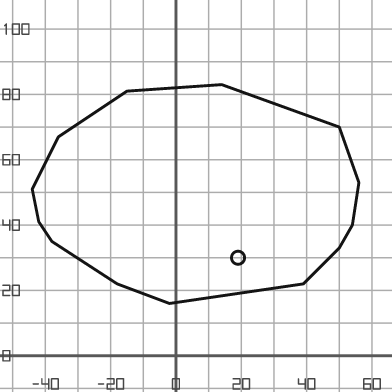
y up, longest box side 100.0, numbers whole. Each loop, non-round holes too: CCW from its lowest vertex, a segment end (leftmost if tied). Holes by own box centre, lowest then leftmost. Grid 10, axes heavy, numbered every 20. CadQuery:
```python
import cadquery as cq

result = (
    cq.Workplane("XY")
    .moveTo(-2.0, 16.0)
    .lineTo(39.0, 22.0)
    .lineTo(50.0, 33.0)
    .lineTo(54.0, 40.0)
    .lineTo(56.0, 53.0)
    .lineTo(50.0, 70.0)
    .lineTo(14.0, 83.0)
    .lineTo(-15.0, 81.0)
    .lineTo(-36.0, 67.0)
    .lineTo(-44.0, 51.0)
    .lineTo(-42.0, 41.0)
    .lineTo(-38.0, 35.0)
    .lineTo(-18.0, 22.0)
    .close()
    .moveTo(19.0, 30.0)
    .circle(2.0)
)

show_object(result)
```